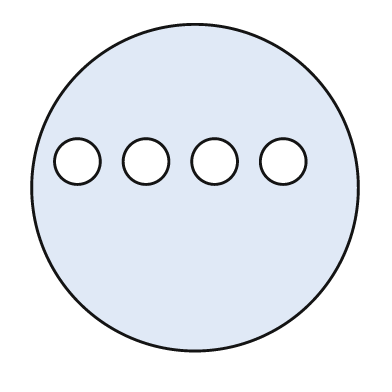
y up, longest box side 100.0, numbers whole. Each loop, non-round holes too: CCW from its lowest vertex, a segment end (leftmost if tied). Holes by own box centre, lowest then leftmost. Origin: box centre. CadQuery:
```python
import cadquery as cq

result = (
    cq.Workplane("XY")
    .moveTo(0.0, 0.0)
    .circle(50.0)
    .moveTo(-36.0, 8.0)
    .circle(7.0)
    .moveTo(-15.0, 8.0)
    .circle(7.0)
    .moveTo(6.0, 8.0)
    .circle(7.0)
    .moveTo(27.0, 8.0)
    .circle(7.0)
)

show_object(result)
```